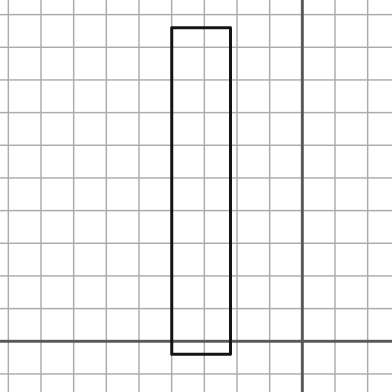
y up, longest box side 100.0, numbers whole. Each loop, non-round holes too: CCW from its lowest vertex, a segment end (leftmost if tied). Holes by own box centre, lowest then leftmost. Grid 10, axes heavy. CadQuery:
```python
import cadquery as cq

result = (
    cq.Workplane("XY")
    .moveTo(-40.0, -4.0)
    .lineTo(-22.0, -4.0)
    .lineTo(-22.0, 96.0)
    .lineTo(-40.0, 96.0)
    .close()
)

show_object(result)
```